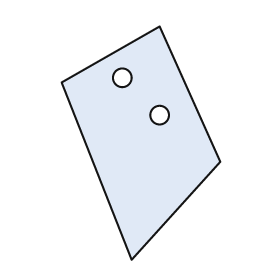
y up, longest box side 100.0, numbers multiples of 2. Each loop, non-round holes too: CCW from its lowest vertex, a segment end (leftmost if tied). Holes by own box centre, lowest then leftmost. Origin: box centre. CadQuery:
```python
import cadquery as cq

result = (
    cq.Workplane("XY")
    .moveTo(-4.0, -50.0)
    .lineTo(34.0, -8.0)
    .lineTo(8.0, 50.0)
    .lineTo(-34.0, 26.0)
    .close()
    .moveTo(8.0, 12.0)
    .circle(4.0)
    .moveTo(-8.0, 28.0)
    .circle(4.0)
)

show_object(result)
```